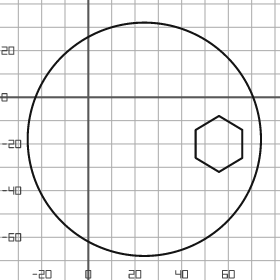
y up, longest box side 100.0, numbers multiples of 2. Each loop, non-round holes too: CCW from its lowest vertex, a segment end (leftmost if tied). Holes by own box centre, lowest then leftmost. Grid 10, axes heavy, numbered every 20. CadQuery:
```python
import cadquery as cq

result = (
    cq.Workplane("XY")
    .moveTo(24.0, -18.0)
    .circle(50.0)
    .moveTo(56.0, -32.0)
    .lineTo(66.0, -26.0)
    .lineTo(66.0, -14.0)
    .lineTo(56.0, -8.0)
    .lineTo(46.0, -14.0)
    .lineTo(46.0, -26.0)
    .close()
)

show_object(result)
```